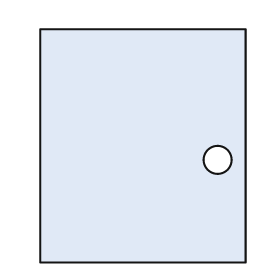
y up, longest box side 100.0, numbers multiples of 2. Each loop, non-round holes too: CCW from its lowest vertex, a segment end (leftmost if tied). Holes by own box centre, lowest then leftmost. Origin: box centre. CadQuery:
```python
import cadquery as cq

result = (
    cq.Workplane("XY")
    .moveTo(-44.0, -50.0)
    .lineTo(44.0, -50.0)
    .lineTo(44.0, 50.0)
    .lineTo(-44.0, 50.0)
    .close()
    .moveTo(32.0, -6.0)
    .circle(6.0)
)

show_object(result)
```